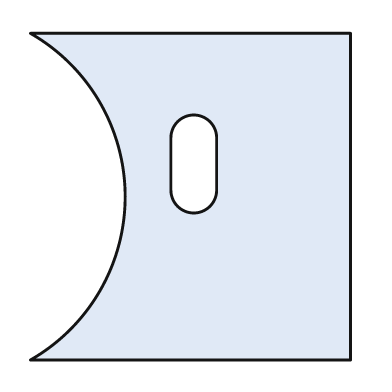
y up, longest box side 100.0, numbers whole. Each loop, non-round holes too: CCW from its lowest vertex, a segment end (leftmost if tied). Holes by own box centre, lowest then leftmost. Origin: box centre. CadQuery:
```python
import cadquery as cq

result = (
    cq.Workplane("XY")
    .moveTo(-49.0, -50.0)
    .lineTo(49.0, -50.0)
    .lineTo(49.0, 50.0)
    .lineTo(-49.0, 50.0)
    .threePointArc((-20.0, 0.0), (-49.0, -50.0))
    .close()
    .moveTo(-6.0, 2.0)
    .threePointArc((1.0, -5.0), (8.0, 2.0))
    .lineTo(8.0, 18.0)
    .threePointArc((1.0, 25.0), (-6.0, 18.0))
    .close()
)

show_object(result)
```